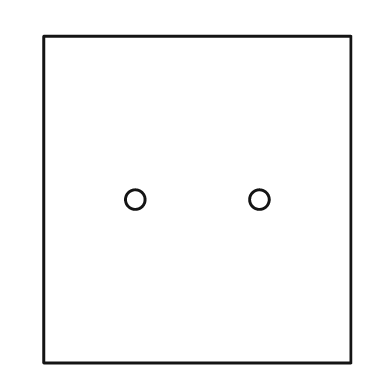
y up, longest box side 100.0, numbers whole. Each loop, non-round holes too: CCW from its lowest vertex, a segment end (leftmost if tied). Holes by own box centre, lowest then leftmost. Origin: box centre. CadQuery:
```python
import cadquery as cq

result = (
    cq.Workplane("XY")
    .moveTo(-47.0, -50.0)
    .lineTo(47.0, -50.0)
    .lineTo(47.0, 50.0)
    .lineTo(-47.0, 50.0)
    .close()
    .moveTo(-19.0, 0.0)
    .circle(3.0)
    .moveTo(19.0, 0.0)
    .circle(3.0)
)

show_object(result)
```